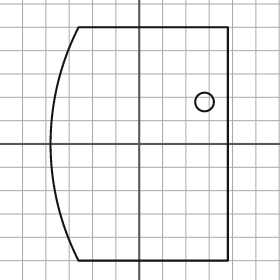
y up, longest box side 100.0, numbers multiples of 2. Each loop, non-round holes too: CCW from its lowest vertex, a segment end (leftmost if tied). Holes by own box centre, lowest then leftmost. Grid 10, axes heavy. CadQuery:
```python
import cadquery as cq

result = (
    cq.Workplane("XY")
    .moveTo(-26.0, -50.0)
    .lineTo(38.0, -50.0)
    .lineTo(38.0, 50.0)
    .lineTo(-26.0, 50.0)
    .threePointArc((-38.0, 0.0), (-26.0, -50.0))
    .close()
    .moveTo(28.0, 18.0)
    .circle(4.0)
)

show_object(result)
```